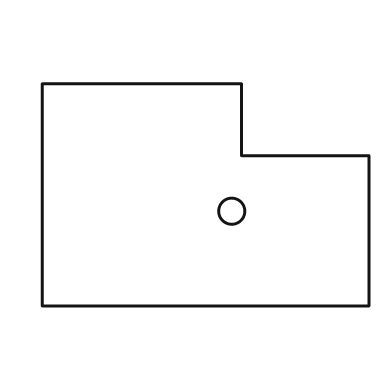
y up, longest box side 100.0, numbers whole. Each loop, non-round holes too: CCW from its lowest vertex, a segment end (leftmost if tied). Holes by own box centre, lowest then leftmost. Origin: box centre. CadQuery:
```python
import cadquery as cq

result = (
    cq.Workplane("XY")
    .moveTo(-50.0, -34.0)
    .lineTo(50.0, -34.0)
    .lineTo(50.0, 12.0)
    .lineTo(11.0, 12.0)
    .lineTo(11.0, 34.0)
    .lineTo(-50.0, 34.0)
    .close()
    .moveTo(8.0, -5.0)
    .circle(4.0)
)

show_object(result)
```